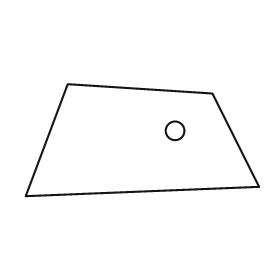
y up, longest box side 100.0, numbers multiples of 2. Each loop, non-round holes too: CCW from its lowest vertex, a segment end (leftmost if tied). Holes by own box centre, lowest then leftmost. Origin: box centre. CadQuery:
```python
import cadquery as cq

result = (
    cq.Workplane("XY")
    .moveTo(-50.0, -24.0)
    .lineTo(50.0, -20.0)
    .lineTo(30.0, 20.0)
    .lineTo(-32.0, 24.0)
    .close()
    .moveTo(14.0, 4.0)
    .circle(4.0)
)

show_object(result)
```